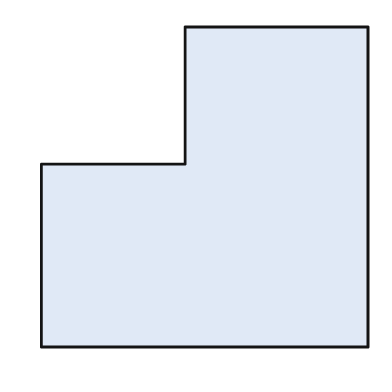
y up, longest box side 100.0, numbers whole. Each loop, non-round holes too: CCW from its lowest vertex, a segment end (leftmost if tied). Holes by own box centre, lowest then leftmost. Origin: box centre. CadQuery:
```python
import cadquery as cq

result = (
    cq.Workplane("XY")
    .moveTo(-50.0, -49.0)
    .lineTo(50.0, -49.0)
    .lineTo(50.0, 49.0)
    .lineTo(-6.0, 49.0)
    .lineTo(-6.0, 7.0)
    .lineTo(-50.0, 7.0)
    .close()
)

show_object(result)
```